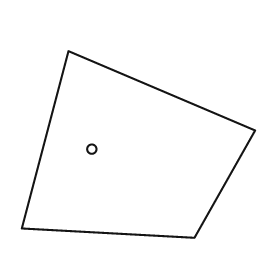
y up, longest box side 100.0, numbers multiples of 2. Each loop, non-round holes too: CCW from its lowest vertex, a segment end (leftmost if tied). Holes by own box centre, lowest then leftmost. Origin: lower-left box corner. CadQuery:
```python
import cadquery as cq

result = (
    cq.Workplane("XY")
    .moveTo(74.0, 0.0)
    .lineTo(100.0, 46.0)
    .lineTo(20.0, 80.0)
    .lineTo(0.0, 4.0)
    .close()
    .moveTo(30.0, 38.0)
    .circle(2.0)
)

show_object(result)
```